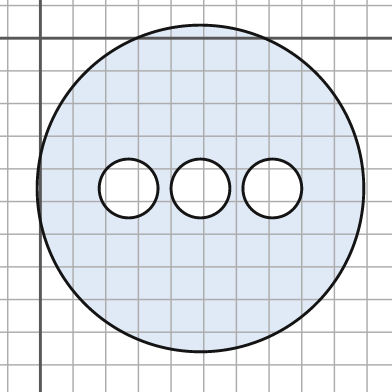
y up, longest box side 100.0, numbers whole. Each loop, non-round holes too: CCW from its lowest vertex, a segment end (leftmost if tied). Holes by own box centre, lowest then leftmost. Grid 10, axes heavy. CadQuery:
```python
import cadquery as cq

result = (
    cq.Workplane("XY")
    .moveTo(49.0, -46.0)
    .circle(50.0)
    .moveTo(27.0, -46.0)
    .circle(9.0)
    .moveTo(49.0, -46.0)
    .circle(9.0)
    .moveTo(71.0, -46.0)
    .circle(9.0)
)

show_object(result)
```